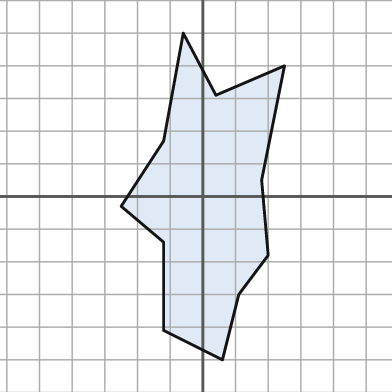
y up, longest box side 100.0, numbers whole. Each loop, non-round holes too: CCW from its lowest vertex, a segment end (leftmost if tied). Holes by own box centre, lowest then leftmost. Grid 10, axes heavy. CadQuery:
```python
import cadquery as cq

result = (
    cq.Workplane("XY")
    .moveTo(6.0, -50.0)
    .lineTo(11.0, -30.0)
    .lineTo(20.0, -18.0)
    .lineTo(18.0, 5.0)
    .lineTo(25.0, 40.0)
    .lineTo(4.0, 31.0)
    .lineTo(-6.0, 50.0)
    .lineTo(-12.0, 17.0)
    .lineTo(-25.0, -3.0)
    .lineTo(-12.0, -14.0)
    .lineTo(-12.0, -41.0)
    .close()
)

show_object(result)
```